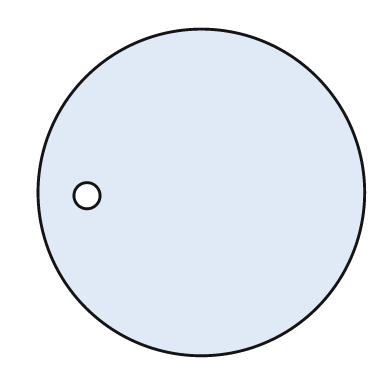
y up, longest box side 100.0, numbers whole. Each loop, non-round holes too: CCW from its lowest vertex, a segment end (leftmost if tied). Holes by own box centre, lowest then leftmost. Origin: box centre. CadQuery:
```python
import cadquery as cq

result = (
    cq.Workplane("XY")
    .moveTo(0.0, 0.0)
    .circle(50.0)
    .moveTo(-35.0, -1.0)
    .circle(4.0)
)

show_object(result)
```